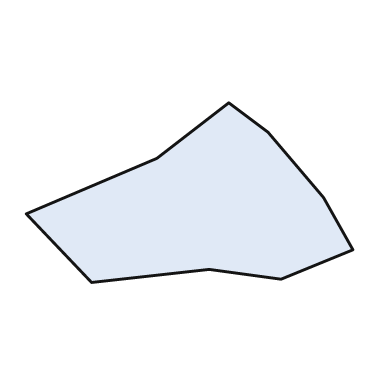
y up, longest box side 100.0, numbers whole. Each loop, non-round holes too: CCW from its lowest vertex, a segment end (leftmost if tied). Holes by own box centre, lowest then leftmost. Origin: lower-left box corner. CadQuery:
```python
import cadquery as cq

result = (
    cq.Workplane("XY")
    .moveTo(20.0, 0.0)
    .lineTo(56.0, 4.0)
    .lineTo(78.0, 1.0)
    .lineTo(100.0, 10.0)
    .lineTo(91.0, 26.0)
    .lineTo(74.0, 46.0)
    .lineTo(62.0, 55.0)
    .lineTo(40.0, 38.0)
    .lineTo(0.0, 21.0)
    .close()
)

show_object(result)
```